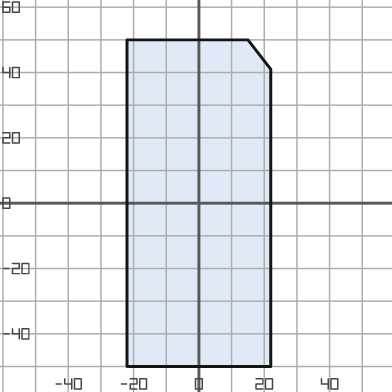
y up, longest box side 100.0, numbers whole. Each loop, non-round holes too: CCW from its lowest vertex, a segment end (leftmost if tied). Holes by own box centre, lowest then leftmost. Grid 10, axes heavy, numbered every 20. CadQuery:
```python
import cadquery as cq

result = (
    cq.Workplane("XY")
    .moveTo(-22.0, -50.0)
    .lineTo(22.0, -50.0)
    .lineTo(22.0, 41.0)
    .lineTo(15.0, 50.0)
    .lineTo(-22.0, 50.0)
    .close()
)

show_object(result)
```